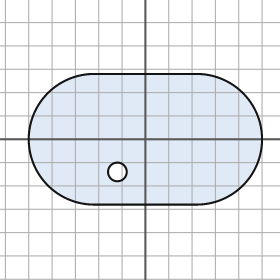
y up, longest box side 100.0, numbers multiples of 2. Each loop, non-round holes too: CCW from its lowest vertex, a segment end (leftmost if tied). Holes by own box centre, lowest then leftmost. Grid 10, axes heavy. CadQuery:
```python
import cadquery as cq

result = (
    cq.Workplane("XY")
    .moveTo(-22.0, -28.0)
    .lineTo(22.0, -28.0)
    .threePointArc((50.0, 0.0), (22.0, 28.0))
    .lineTo(-22.0, 28.0)
    .threePointArc((-50.0, 0.0), (-22.0, -28.0))
    .close()
    .moveTo(-12.0, -14.0)
    .circle(4.0)
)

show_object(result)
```